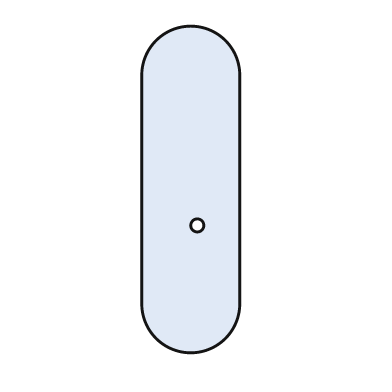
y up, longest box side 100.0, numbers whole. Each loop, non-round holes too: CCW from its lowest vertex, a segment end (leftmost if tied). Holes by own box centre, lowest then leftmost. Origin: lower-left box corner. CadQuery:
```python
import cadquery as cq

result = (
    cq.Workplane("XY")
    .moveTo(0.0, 15.0)
    .threePointArc((15.0, 0.0), (30.0, 15.0))
    .lineTo(30.0, 85.0)
    .threePointArc((15.0, 100.0), (0.0, 85.0))
    .close()
    .moveTo(17.0, 39.0)
    .circle(2.0)
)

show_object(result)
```